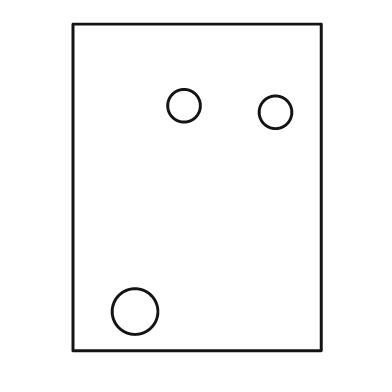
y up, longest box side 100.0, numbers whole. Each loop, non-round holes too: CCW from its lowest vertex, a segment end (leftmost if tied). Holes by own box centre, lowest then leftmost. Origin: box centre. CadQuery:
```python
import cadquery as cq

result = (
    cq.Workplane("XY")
    .moveTo(-38.0, -50.0)
    .lineTo(38.0, -50.0)
    .lineTo(38.0, 50.0)
    .lineTo(-38.0, 50.0)
    .close()
    .moveTo(-19.0, -38.0)
    .circle(7.0)
    .moveTo(24.0, 23.0)
    .circle(5.0)
    .moveTo(-4.0, 25.0)
    .circle(5.0)
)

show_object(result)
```